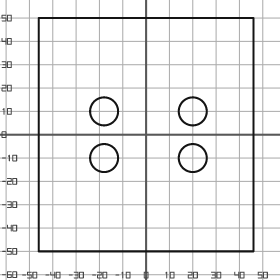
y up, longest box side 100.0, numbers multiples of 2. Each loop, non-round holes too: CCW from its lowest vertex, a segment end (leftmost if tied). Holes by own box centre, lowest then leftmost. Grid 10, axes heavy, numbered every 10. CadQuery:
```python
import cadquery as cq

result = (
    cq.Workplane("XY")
    .moveTo(-46.0, -50.0)
    .lineTo(46.0, -50.0)
    .lineTo(46.0, 50.0)
    .lineTo(-46.0, 50.0)
    .close()
    .moveTo(-18.0, -10.0)
    .circle(6.0)
    .moveTo(20.0, -10.0)
    .circle(6.0)
    .moveTo(-18.0, 10.0)
    .circle(6.0)
    .moveTo(20.0, 10.0)
    .circle(6.0)
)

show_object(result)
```